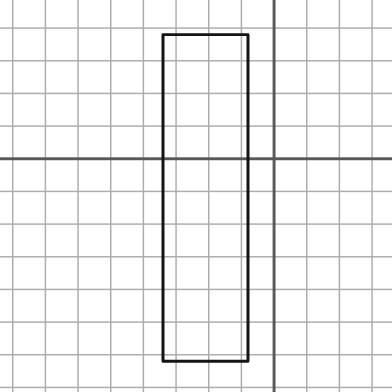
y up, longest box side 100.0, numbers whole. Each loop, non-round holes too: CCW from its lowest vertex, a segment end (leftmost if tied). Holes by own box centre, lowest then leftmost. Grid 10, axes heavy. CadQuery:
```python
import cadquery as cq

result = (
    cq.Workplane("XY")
    .moveTo(-34.0, -62.0)
    .lineTo(-8.0, -62.0)
    .lineTo(-8.0, 38.0)
    .lineTo(-34.0, 38.0)
    .close()
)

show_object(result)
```